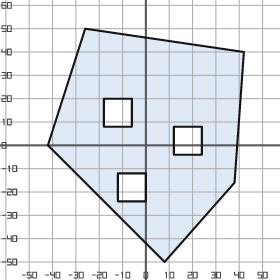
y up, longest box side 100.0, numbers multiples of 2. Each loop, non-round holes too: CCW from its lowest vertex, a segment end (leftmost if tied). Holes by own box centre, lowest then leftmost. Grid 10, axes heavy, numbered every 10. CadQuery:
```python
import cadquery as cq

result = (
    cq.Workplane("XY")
    .moveTo(8.0, -50.0)
    .lineTo(38.0, -16.0)
    .lineTo(42.0, 40.0)
    .lineTo(-26.0, 50.0)
    .lineTo(-42.0, 0.0)
    .close()
    .moveTo(-12.0, -24.0)
    .lineTo(0.0, -24.0)
    .lineTo(0.0, -12.0)
    .lineTo(-12.0, -12.0)
    .close()
    .moveTo(12.0, -4.0)
    .lineTo(24.0, -4.0)
    .lineTo(24.0, 8.0)
    .lineTo(12.0, 8.0)
    .close()
    .moveTo(-18.0, 8.0)
    .lineTo(-6.0, 8.0)
    .lineTo(-6.0, 20.0)
    .lineTo(-18.0, 20.0)
    .close()
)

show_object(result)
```